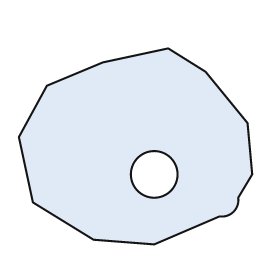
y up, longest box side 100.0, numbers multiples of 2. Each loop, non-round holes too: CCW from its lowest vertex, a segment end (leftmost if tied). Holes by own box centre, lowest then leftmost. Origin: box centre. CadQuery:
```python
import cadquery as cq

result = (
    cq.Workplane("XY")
    .moveTo(8.0, -42.0)
    .lineTo(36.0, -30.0)
    .threePointArc((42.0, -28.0), (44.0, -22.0))
    .lineTo(50.0, -12.0)
    .lineTo(48.0, 10.0)
    .lineTo(30.0, 32.0)
    .lineTo(14.0, 42.0)
    .lineTo(-14.0, 36.0)
    .lineTo(-38.0, 26.0)
    .lineTo(-50.0, 4.0)
    .lineTo(-44.0, -24.0)
    .lineTo(-18.0, -40.0)
    .close()
    .moveTo(8.0, -12.0)
    .circle(10.0)
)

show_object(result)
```